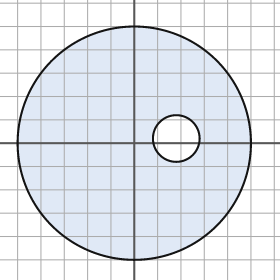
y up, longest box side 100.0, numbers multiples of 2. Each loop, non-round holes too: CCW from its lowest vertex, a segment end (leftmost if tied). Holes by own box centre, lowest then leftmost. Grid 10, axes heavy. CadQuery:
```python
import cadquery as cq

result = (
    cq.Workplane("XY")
    .moveTo(0.0, 0.0)
    .circle(50.0)
    .moveTo(18.0, 2.0)
    .circle(10.0)
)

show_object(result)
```